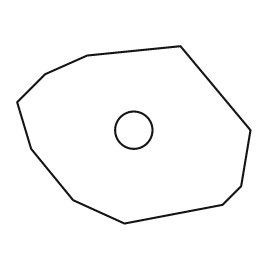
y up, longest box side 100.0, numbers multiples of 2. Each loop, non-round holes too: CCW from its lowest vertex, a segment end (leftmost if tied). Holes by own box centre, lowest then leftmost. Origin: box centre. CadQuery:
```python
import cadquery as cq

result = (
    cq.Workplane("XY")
    .moveTo(-4.0, -38.0)
    .lineTo(38.0, -30.0)
    .lineTo(46.0, -22.0)
    .lineTo(50.0, 2.0)
    .lineTo(20.0, 38.0)
    .lineTo(-20.0, 34.0)
    .lineTo(-38.0, 26.0)
    .lineTo(-50.0, 14.0)
    .lineTo(-44.0, -6.0)
    .lineTo(-26.0, -28.0)
    .close()
    .moveTo(0.0, 2.0)
    .circle(8.0)
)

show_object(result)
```